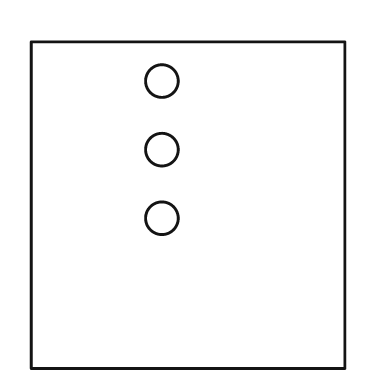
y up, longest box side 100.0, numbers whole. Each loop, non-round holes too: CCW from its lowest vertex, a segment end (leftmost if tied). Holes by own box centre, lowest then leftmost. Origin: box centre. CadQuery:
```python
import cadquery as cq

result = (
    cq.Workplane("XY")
    .moveTo(-48.0, -50.0)
    .lineTo(48.0, -50.0)
    .lineTo(48.0, 50.0)
    .lineTo(-48.0, 50.0)
    .close()
    .moveTo(-8.0, -4.0)
    .circle(5.0)
    .moveTo(-8.0, 17.0)
    .circle(5.0)
    .moveTo(-8.0, 38.0)
    .circle(5.0)
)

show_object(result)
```